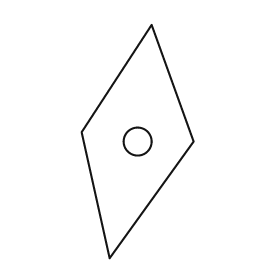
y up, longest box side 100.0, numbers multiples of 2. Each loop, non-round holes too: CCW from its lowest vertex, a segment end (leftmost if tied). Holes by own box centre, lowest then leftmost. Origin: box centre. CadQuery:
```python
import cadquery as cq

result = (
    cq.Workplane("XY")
    .moveTo(-12.0, -50.0)
    .lineTo(24.0, 0.0)
    .lineTo(6.0, 50.0)
    .lineTo(-24.0, 4.0)
    .close()
    .moveTo(0.0, 0.0)
    .circle(6.0)
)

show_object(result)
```